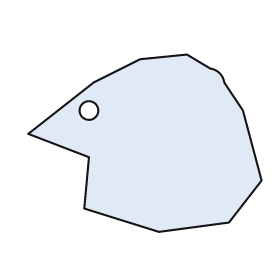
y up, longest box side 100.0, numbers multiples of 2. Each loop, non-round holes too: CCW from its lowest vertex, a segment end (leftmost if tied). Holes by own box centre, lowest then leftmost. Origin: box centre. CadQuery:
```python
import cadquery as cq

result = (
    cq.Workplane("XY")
    .moveTo(6.0, -38.0)
    .lineTo(36.0, -34.0)
    .lineTo(50.0, -16.0)
    .lineTo(42.0, 14.0)
    .lineTo(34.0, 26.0)
    .threePointArc((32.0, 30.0), (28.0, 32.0))
    .lineTo(18.0, 38.0)
    .lineTo(-2.0, 36.0)
    .lineTo(-22.0, 26.0)
    .lineTo(-50.0, 4.0)
    .lineTo(-24.0, -6.0)
    .lineTo(-26.0, -28.0)
    .close()
    .moveTo(-24.0, 14.0)
    .circle(4.0)
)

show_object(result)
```